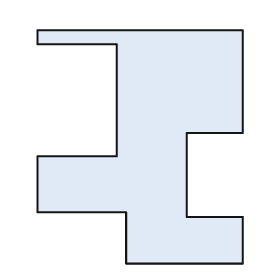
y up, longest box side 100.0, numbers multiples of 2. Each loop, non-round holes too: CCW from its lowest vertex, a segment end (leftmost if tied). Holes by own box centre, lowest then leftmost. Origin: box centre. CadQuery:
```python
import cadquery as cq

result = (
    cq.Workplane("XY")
    .moveTo(-6.0, -50.0)
    .lineTo(44.0, -50.0)
    .lineTo(44.0, -30.0)
    .lineTo(20.0, -30.0)
    .lineTo(20.0, 6.0)
    .lineTo(44.0, 6.0)
    .lineTo(44.0, 50.0)
    .lineTo(-44.0, 50.0)
    .lineTo(-44.0, 44.0)
    .lineTo(-10.0, 44.0)
    .lineTo(-10.0, -4.0)
    .lineTo(-44.0, -4.0)
    .lineTo(-44.0, -28.0)
    .lineTo(-6.0, -28.0)
    .close()
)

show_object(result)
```